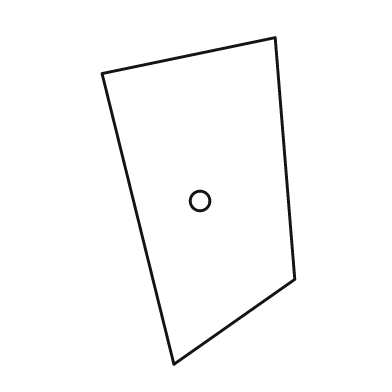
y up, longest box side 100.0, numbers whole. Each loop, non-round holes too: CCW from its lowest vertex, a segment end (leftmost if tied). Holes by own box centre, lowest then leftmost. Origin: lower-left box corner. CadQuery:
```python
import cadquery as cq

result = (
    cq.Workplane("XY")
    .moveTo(22.0, 0.0)
    .lineTo(59.0, 26.0)
    .lineTo(53.0, 100.0)
    .lineTo(0.0, 89.0)
    .close()
    .moveTo(30.0, 50.0)
    .circle(3.0)
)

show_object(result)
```